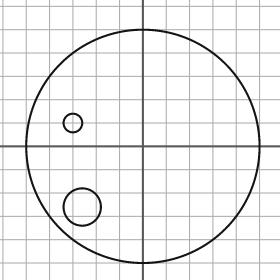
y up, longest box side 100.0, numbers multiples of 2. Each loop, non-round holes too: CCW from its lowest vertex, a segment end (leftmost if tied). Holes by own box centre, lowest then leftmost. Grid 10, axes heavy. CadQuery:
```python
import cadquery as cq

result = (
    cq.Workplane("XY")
    .moveTo(0.0, 0.0)
    .circle(50.0)
    .moveTo(-26.0, -26.0)
    .circle(8.0)
    .moveTo(-30.0, 10.0)
    .circle(4.0)
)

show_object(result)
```